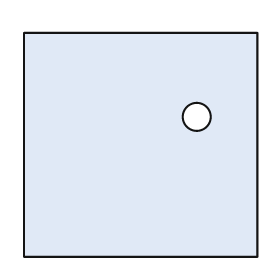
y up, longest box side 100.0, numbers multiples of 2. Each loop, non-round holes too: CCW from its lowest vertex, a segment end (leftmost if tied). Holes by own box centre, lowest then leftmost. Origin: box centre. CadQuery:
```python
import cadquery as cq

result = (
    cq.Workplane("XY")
    .moveTo(-50.0, -48.0)
    .lineTo(50.0, -48.0)
    .lineTo(50.0, 48.0)
    .lineTo(-50.0, 48.0)
    .close()
    .moveTo(24.0, 12.0)
    .circle(6.0)
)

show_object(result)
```